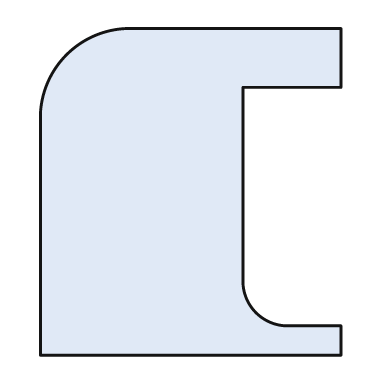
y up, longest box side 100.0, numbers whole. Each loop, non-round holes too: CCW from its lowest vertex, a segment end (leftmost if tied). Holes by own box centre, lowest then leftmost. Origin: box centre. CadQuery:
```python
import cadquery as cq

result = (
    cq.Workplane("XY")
    .moveTo(-46.0, -50.0)
    .lineTo(46.0, -50.0)
    .lineTo(46.0, -41.0)
    .lineTo(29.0, -41.0)
    .threePointArc((20.0, -37.0), (16.0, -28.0))
    .lineTo(16.0, 32.0)
    .lineTo(46.0, 32.0)
    .lineTo(46.0, 50.0)
    .lineTo(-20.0, 50.0)
    .threePointArc((-38.0, 42.0), (-46.0, 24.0))
    .close()
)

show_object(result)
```